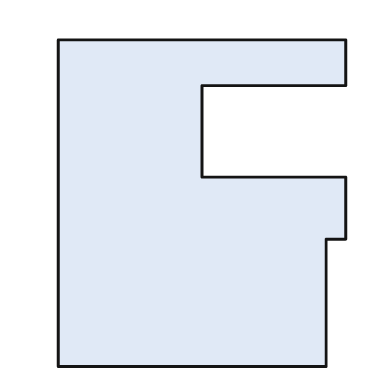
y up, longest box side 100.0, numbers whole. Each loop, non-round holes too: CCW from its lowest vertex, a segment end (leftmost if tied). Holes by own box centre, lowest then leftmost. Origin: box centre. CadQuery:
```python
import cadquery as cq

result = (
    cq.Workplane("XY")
    .moveTo(-44.0, -50.0)
    .lineTo(38.0, -50.0)
    .lineTo(38.0, -11.0)
    .lineTo(44.0, -11.0)
    .lineTo(44.0, 8.0)
    .lineTo(0.0, 8.0)
    .lineTo(0.0, 36.0)
    .lineTo(44.0, 36.0)
    .lineTo(44.0, 50.0)
    .lineTo(-44.0, 50.0)
    .close()
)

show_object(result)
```